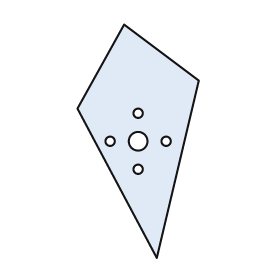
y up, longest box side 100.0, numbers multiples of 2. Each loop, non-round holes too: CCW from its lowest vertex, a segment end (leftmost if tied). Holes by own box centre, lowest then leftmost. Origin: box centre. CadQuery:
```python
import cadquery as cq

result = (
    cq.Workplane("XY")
    .moveTo(8.0, -50.0)
    .lineTo(26.0, 26.0)
    .lineTo(-6.0, 50.0)
    .lineTo(-26.0, 14.0)
    .close()
    .moveTo(0.0, -12.0)
    .circle(2.0)
    .moveTo(-12.0, 0.0)
    .circle(2.0)
    .moveTo(0.0, 0.0)
    .circle(4.0)
    .moveTo(12.0, 0.0)
    .circle(2.0)
    .moveTo(0.0, 12.0)
    .circle(2.0)
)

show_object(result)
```